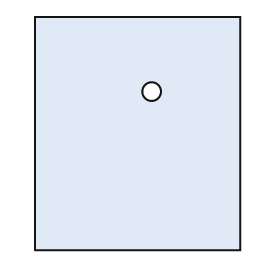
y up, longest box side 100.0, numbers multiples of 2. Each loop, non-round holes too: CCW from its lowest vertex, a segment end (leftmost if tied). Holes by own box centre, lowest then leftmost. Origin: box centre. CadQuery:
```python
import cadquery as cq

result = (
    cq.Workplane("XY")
    .moveTo(-44.0, -50.0)
    .lineTo(44.0, -50.0)
    .lineTo(44.0, 50.0)
    .lineTo(-44.0, 50.0)
    .close()
    .moveTo(6.0, 18.0)
    .circle(4.0)
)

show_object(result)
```